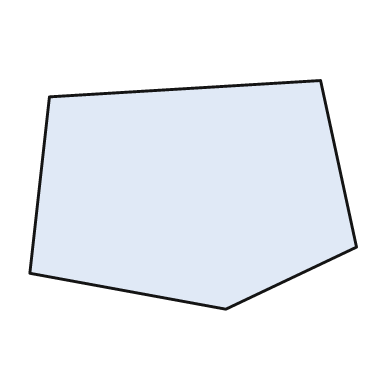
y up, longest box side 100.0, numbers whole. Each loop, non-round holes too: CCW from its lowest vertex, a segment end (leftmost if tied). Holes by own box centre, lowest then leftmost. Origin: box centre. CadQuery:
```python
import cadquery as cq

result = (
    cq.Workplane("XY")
    .moveTo(10.0, -35.0)
    .lineTo(50.0, -16.0)
    .lineTo(39.0, 35.0)
    .lineTo(-44.0, 30.0)
    .lineTo(-50.0, -24.0)
    .close()
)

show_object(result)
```